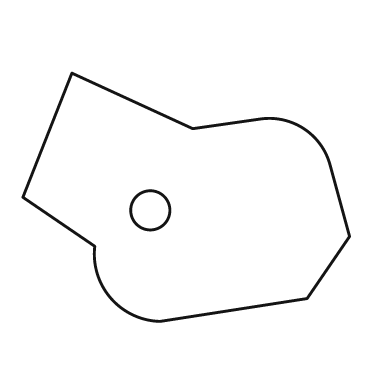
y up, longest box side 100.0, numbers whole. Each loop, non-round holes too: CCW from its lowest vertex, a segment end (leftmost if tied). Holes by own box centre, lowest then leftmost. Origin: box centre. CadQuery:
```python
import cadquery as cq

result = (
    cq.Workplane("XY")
    .moveTo(-8.0, -38.0)
    .lineTo(37.0, -31.0)
    .lineTo(50.0, -12.0)
    .lineTo(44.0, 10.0)
    .threePointArc((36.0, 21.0), (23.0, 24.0))
    .lineTo(2.0, 21.0)
    .lineTo(-35.0, 38.0)
    .lineTo(-50.0, 0.0)
    .lineTo(-28.0, -15.0)
    .threePointArc((-23.0, -31.0), (-8.0, -38.0))
    .close()
    .moveTo(-11.0, -4.0)
    .circle(6.0)
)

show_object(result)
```